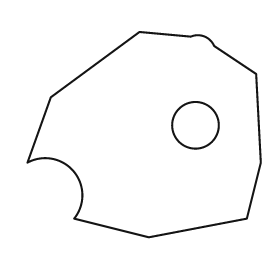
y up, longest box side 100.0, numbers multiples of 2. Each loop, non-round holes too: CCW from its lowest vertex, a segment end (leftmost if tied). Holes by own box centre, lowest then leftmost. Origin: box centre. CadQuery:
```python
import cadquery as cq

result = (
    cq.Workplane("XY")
    .moveTo(2.0, -44.0)
    .lineTo(44.0, -36.0)
    .lineTo(50.0, -12.0)
    .lineTo(48.0, 26.0)
    .lineTo(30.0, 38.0)
    .threePointArc((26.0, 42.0), (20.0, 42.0))
    .lineTo(-2.0, 44.0)
    .lineTo(-40.0, 16.0)
    .lineTo(-50.0, -12.0)
    .threePointArc((-30.0, -16.0), (-30.0, -36.0))
    .close()
    .moveTo(22.0, 4.0)
    .circle(10.0)
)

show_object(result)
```